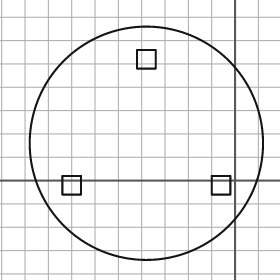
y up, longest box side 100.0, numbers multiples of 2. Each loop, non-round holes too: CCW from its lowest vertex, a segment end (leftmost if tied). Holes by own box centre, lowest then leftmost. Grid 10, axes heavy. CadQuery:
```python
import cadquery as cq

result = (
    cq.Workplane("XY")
    .moveTo(-38.0, 16.0)
    .circle(50.0)
    .moveTo(-74.0, -6.0)
    .lineTo(-66.0, -6.0)
    .lineTo(-66.0, 2.0)
    .lineTo(-74.0, 2.0)
    .close()
    .moveTo(-10.0, -6.0)
    .lineTo(-2.0, -6.0)
    .lineTo(-2.0, 2.0)
    .lineTo(-10.0, 2.0)
    .close()
    .moveTo(-42.0, 48.0)
    .lineTo(-34.0, 48.0)
    .lineTo(-34.0, 56.0)
    .lineTo(-42.0, 56.0)
    .close()
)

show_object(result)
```